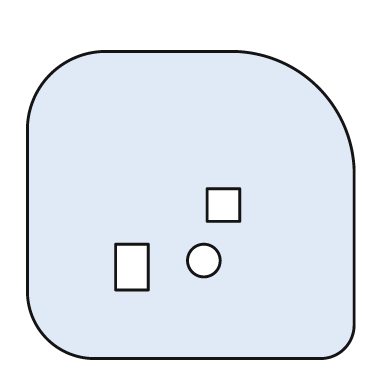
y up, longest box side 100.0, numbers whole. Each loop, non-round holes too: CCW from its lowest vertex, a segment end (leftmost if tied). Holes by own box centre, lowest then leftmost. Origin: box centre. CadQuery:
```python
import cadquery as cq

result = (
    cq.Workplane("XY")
    .moveTo(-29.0, -47.0)
    .lineTo(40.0, -47.0)
    .threePointArc((47.0, -44.0), (50.0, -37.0))
    .lineTo(50.0, 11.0)
    .threePointArc((39.0, 36.0), (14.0, 47.0))
    .lineTo(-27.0, 47.0)
    .threePointArc((-43.0, 40.0), (-50.0, 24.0))
    .lineTo(-50.0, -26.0)
    .threePointArc((-44.0, -41.0), (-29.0, -47.0))
    .close()
    .moveTo(-23.0, -26.0)
    .lineTo(-13.0, -26.0)
    .lineTo(-13.0, -12.0)
    .lineTo(-23.0, -12.0)
    .close()
    .moveTo(4.0, -17.0)
    .circle(5.0)
    .moveTo(5.0, -5.0)
    .lineTo(15.0, -5.0)
    .lineTo(15.0, 5.0)
    .lineTo(5.0, 5.0)
    .close()
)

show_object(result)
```